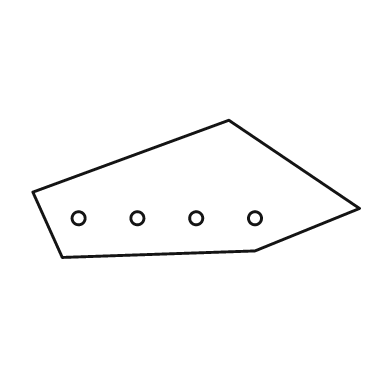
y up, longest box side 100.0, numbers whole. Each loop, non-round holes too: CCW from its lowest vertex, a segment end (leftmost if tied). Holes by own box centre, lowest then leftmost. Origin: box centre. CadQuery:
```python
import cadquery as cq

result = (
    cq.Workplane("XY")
    .moveTo(-41.0, -21.0)
    .lineTo(18.0, -19.0)
    .lineTo(50.0, -6.0)
    .lineTo(10.0, 21.0)
    .lineTo(-50.0, -1.0)
    .close()
    .moveTo(-36.0, -9.0)
    .circle(2.0)
    .moveTo(-18.0, -9.0)
    .circle(2.0)
    .moveTo(0.0, -9.0)
    .circle(2.0)
    .moveTo(18.0, -9.0)
    .circle(2.0)
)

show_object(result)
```